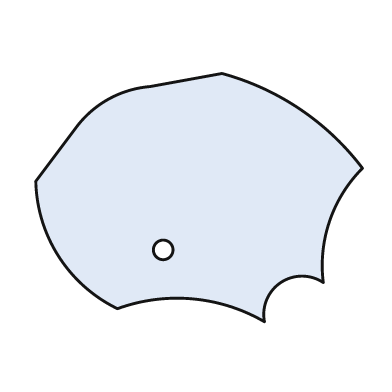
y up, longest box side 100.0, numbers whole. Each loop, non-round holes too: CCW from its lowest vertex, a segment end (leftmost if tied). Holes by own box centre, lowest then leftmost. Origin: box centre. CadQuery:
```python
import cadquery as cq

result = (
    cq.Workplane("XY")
    .moveTo(20.0, -38.0)
    .threePointArc((25.0, -26.0), (38.0, -26.0))
    .threePointArc((40.0, -7.0), (50.0, 9.0))
    .threePointArc((31.0, 27.0), (7.0, 38.0))
    .lineTo(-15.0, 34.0)
    .threePointArc((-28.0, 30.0), (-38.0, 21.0))
    .lineTo(-50.0, 5.0)
    .threePointArc((-43.0, -18.0), (-25.0, -34.0))
    .threePointArc((-2.0, -31.0), (20.0, -38.0))
    .close()
    .moveTo(-11.0, -16.0)
    .circle(3.0)
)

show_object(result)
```